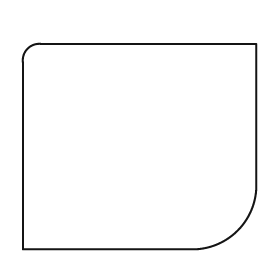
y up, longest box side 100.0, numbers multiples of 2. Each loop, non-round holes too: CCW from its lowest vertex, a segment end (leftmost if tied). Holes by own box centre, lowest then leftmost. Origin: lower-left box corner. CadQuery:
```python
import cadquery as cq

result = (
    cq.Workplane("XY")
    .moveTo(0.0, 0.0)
    .lineTo(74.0, 0.0)
    .threePointArc((92.0, 8.0), (100.0, 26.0))
    .lineTo(100.0, 88.0)
    .lineTo(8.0, 88.0)
    .threePointArc((2.0, 86.0), (0.0, 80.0))
    .close()
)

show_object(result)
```